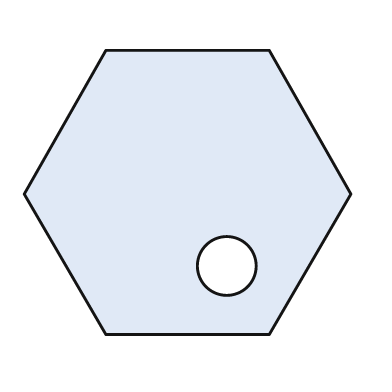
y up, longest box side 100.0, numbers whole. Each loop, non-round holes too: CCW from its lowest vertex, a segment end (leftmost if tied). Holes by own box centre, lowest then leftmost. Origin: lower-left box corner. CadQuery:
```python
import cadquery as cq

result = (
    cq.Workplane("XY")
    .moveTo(25.0, 0.0)
    .lineTo(75.0, 0.0)
    .lineTo(100.0, 43.0)
    .lineTo(75.0, 87.0)
    .lineTo(25.0, 87.0)
    .lineTo(0.0, 43.0)
    .close()
    .moveTo(62.0, 21.0)
    .circle(9.0)
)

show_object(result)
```